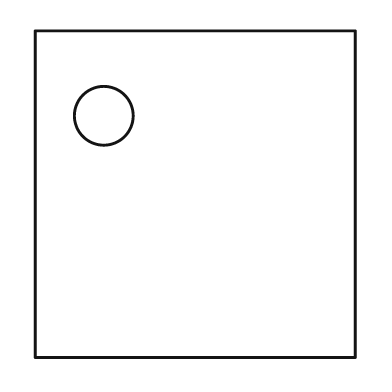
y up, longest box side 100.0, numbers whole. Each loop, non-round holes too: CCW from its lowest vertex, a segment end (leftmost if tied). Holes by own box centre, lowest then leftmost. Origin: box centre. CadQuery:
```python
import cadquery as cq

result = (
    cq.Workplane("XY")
    .moveTo(-49.0, -50.0)
    .lineTo(49.0, -50.0)
    .lineTo(49.0, 50.0)
    .lineTo(-49.0, 50.0)
    .close()
    .moveTo(-28.0, 24.0)
    .circle(9.0)
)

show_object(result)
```